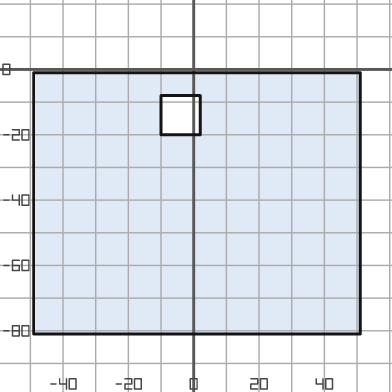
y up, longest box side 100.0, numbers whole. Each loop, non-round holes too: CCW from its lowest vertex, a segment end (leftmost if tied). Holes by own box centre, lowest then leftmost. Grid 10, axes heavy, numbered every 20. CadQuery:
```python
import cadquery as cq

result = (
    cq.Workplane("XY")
    .moveTo(-49.0, -81.0)
    .lineTo(51.0, -81.0)
    .lineTo(51.0, -1.0)
    .lineTo(-49.0, -1.0)
    .close()
    .moveTo(-10.0, -20.0)
    .lineTo(2.0, -20.0)
    .lineTo(2.0, -8.0)
    .lineTo(-10.0, -8.0)
    .close()
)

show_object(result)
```